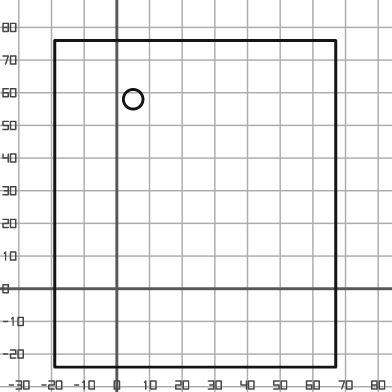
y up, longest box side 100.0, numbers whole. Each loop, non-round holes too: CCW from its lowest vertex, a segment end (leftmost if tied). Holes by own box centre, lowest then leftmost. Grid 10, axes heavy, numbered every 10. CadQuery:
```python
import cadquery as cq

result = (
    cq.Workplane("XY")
    .moveTo(-19.0, -24.0)
    .lineTo(67.0, -24.0)
    .lineTo(67.0, 76.0)
    .lineTo(-19.0, 76.0)
    .close()
    .moveTo(5.0, 58.0)
    .circle(3.0)
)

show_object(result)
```